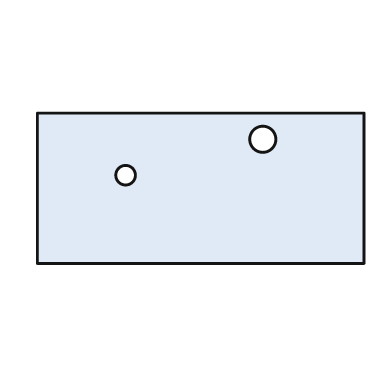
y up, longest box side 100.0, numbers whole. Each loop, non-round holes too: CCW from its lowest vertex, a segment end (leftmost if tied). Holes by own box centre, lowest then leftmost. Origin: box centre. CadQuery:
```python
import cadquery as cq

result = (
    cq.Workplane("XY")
    .moveTo(-50.0, -23.0)
    .lineTo(50.0, -23.0)
    .lineTo(50.0, 23.0)
    .lineTo(-50.0, 23.0)
    .close()
    .moveTo(-23.0, 4.0)
    .circle(3.0)
    .moveTo(19.0, 15.0)
    .circle(4.0)
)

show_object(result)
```